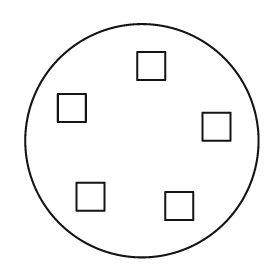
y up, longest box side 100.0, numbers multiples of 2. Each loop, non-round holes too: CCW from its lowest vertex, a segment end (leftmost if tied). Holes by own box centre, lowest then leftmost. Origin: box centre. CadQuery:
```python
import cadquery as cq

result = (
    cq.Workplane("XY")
    .moveTo(0.0, 0.0)
    .circle(50.0)
    .moveTo(10.0, -34.0)
    .lineTo(22.0, -34.0)
    .lineTo(22.0, -22.0)
    .lineTo(10.0, -22.0)
    .close()
    .moveTo(-28.0, -30.0)
    .lineTo(-16.0, -30.0)
    .lineTo(-16.0, -18.0)
    .lineTo(-28.0, -18.0)
    .close()
    .moveTo(26.0, 0.0)
    .lineTo(38.0, 0.0)
    .lineTo(38.0, 12.0)
    .lineTo(26.0, 12.0)
    .close()
    .moveTo(-36.0, 8.0)
    .lineTo(-24.0, 8.0)
    .lineTo(-24.0, 20.0)
    .lineTo(-36.0, 20.0)
    .close()
    .moveTo(-2.0, 26.0)
    .lineTo(10.0, 26.0)
    .lineTo(10.0, 38.0)
    .lineTo(-2.0, 38.0)
    .close()
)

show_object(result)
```